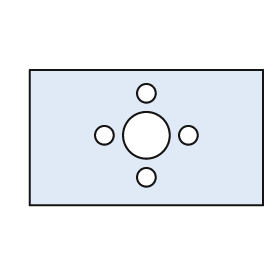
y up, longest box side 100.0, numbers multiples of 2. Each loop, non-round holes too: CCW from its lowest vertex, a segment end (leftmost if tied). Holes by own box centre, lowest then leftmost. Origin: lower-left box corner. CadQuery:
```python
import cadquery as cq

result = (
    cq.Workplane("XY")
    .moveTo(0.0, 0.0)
    .lineTo(100.0, 0.0)
    .lineTo(100.0, 58.0)
    .lineTo(0.0, 58.0)
    .close()
    .moveTo(50.0, 12.0)
    .circle(4.0)
    .moveTo(32.0, 30.0)
    .circle(4.0)
    .moveTo(50.0, 30.0)
    .circle(10.0)
    .moveTo(68.0, 30.0)
    .circle(4.0)
    .moveTo(50.0, 48.0)
    .circle(4.0)
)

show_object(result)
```